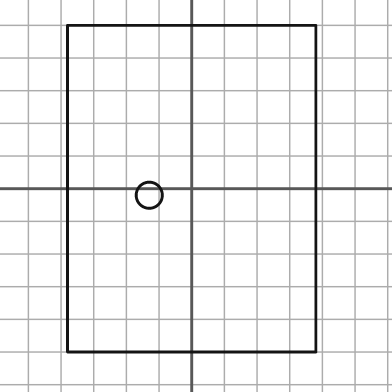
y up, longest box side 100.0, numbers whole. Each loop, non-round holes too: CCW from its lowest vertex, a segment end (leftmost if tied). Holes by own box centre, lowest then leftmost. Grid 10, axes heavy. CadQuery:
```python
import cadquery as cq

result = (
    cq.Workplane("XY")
    .moveTo(-38.0, -50.0)
    .lineTo(38.0, -50.0)
    .lineTo(38.0, 50.0)
    .lineTo(-38.0, 50.0)
    .close()
    .moveTo(-13.0, -2.0)
    .circle(4.0)
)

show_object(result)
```